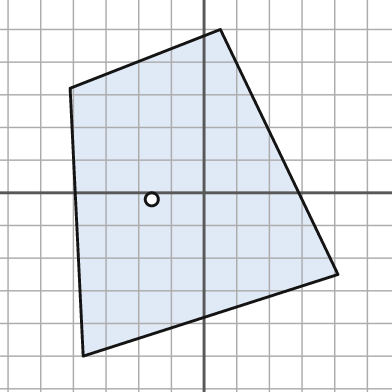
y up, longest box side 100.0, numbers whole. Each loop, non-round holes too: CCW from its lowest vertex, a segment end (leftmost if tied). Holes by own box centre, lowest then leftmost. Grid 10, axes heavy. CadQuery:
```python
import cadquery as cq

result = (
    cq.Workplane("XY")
    .moveTo(-37.0, -50.0)
    .lineTo(41.0, -25.0)
    .lineTo(5.0, 50.0)
    .lineTo(-41.0, 32.0)
    .close()
    .moveTo(-16.0, -2.0)
    .circle(2.0)
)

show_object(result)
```